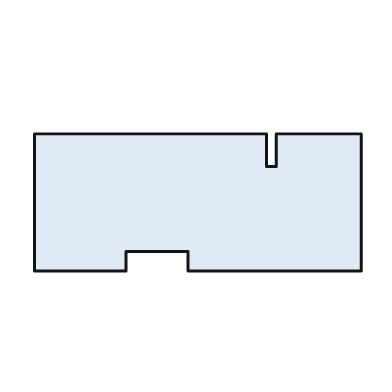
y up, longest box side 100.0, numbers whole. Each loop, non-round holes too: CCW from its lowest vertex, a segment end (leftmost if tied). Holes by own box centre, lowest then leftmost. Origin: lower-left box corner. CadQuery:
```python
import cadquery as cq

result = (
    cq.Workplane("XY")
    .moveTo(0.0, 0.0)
    .lineTo(28.0, 0.0)
    .lineTo(28.0, 6.0)
    .lineTo(47.0, 6.0)
    .lineTo(47.0, 0.0)
    .lineTo(100.0, 0.0)
    .lineTo(100.0, 42.0)
    .lineTo(74.0, 42.0)
    .lineTo(74.0, 32.0)
    .lineTo(71.0, 32.0)
    .lineTo(71.0, 42.0)
    .lineTo(0.0, 42.0)
    .close()
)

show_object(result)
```